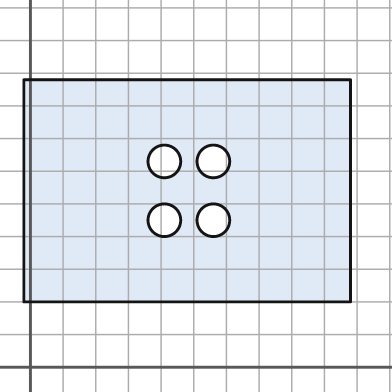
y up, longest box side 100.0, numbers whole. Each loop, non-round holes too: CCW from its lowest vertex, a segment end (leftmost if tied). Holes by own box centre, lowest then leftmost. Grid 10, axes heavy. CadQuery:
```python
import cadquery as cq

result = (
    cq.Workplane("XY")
    .moveTo(-2.0, 20.0)
    .lineTo(98.0, 20.0)
    .lineTo(98.0, 88.0)
    .lineTo(-2.0, 88.0)
    .close()
    .moveTo(41.0, 45.0)
    .circle(5.0)
    .moveTo(56.0, 45.0)
    .circle(5.0)
    .moveTo(41.0, 63.0)
    .circle(5.0)
    .moveTo(56.0, 63.0)
    .circle(5.0)
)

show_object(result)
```